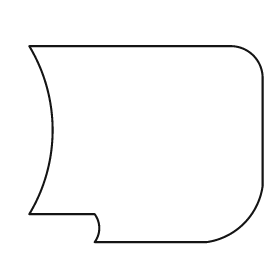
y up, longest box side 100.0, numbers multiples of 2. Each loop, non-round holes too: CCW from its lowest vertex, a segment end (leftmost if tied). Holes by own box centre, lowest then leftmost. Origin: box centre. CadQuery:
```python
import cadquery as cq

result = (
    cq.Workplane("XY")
    .moveTo(-22.0, -42.0)
    .lineTo(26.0, -42.0)
    .threePointArc((42.0, -34.0), (50.0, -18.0))
    .lineTo(50.0, 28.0)
    .threePointArc((46.0, 38.0), (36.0, 42.0))
    .lineTo(-50.0, 42.0)
    .threePointArc((-40.0, 6.0), (-50.0, -30.0))
    .lineTo(-22.0, -30.0)
    .threePointArc((-20.0, -36.0), (-22.0, -42.0))
    .close()
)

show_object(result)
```